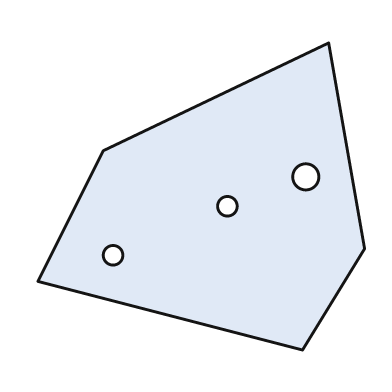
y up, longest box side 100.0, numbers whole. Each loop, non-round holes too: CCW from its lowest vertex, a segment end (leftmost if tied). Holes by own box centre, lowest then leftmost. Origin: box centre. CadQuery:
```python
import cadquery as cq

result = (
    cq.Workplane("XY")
    .moveTo(31.0, -47.0)
    .lineTo(50.0, -16.0)
    .lineTo(39.0, 47.0)
    .lineTo(-30.0, 14.0)
    .lineTo(-50.0, -26.0)
    .close()
    .moveTo(-27.0, -18.0)
    .circle(3.0)
    .moveTo(8.0, -3.0)
    .circle(3.0)
    .moveTo(32.0, 6.0)
    .circle(4.0)
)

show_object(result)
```